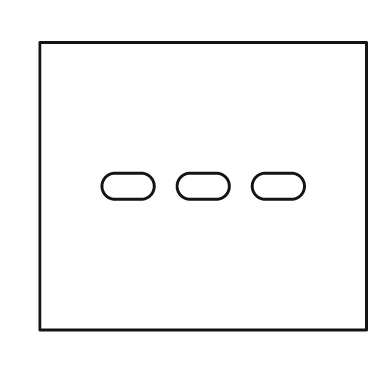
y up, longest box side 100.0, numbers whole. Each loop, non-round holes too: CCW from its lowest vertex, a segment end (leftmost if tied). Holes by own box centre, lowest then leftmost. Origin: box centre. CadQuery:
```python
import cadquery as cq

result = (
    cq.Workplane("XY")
    .moveTo(-50.0, -44.0)
    .lineTo(50.0, -44.0)
    .lineTo(50.0, 44.0)
    .lineTo(-50.0, 44.0)
    .close()
    .moveTo(-27.0, -4.0)
    .lineTo(-19.0, -4.0)
    .threePointArc((-15.0, 0.0), (-19.0, 4.0))
    .lineTo(-27.0, 4.0)
    .threePointArc((-31.0, 0.0), (-27.0, -4.0))
    .close()
    .moveTo(-4.0, -4.0)
    .lineTo(4.0, -4.0)
    .threePointArc((8.0, 0.0), (4.0, 4.0))
    .lineTo(-4.0, 4.0)
    .threePointArc((-8.0, 0.0), (-4.0, -4.0))
    .close()
    .moveTo(19.0, -4.0)
    .lineTo(27.0, -4.0)
    .threePointArc((31.0, 0.0), (27.0, 4.0))
    .lineTo(19.0, 4.0)
    .threePointArc((15.0, 0.0), (19.0, -4.0))
    .close()
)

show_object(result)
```